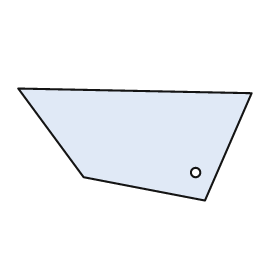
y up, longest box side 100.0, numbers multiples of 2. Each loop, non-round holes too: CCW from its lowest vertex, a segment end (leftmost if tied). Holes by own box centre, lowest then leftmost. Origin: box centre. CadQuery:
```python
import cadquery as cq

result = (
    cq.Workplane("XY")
    .moveTo(30.0, -24.0)
    .lineTo(50.0, 22.0)
    .lineTo(-50.0, 24.0)
    .lineTo(-22.0, -14.0)
    .close()
    .moveTo(26.0, -12.0)
    .circle(2.0)
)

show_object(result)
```